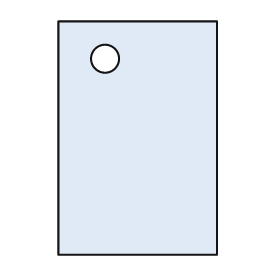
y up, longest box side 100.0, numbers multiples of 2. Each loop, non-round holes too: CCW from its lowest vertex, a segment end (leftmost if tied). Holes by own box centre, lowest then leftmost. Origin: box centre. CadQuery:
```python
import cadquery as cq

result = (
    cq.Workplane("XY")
    .moveTo(-34.0, -50.0)
    .lineTo(34.0, -50.0)
    .lineTo(34.0, 50.0)
    .lineTo(-34.0, 50.0)
    .close()
    .moveTo(-14.0, 34.0)
    .circle(6.0)
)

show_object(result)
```